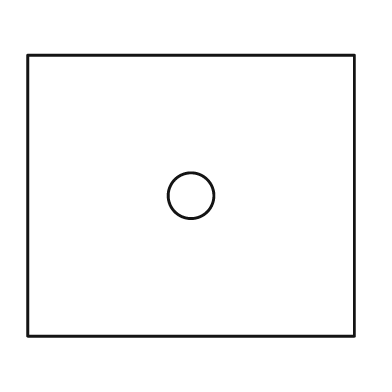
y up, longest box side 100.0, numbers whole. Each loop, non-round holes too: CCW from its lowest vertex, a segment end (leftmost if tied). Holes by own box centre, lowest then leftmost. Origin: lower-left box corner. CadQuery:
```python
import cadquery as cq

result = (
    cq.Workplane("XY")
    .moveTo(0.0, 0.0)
    .lineTo(100.0, 0.0)
    .lineTo(100.0, 86.0)
    .lineTo(0.0, 86.0)
    .close()
    .moveTo(50.0, 43.0)
    .circle(7.0)
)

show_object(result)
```